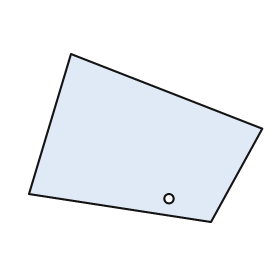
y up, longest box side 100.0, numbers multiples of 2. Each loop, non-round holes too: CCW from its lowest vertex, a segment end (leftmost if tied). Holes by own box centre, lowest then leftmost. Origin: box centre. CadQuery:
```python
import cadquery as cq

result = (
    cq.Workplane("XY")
    .moveTo(28.0, -36.0)
    .lineTo(50.0, 4.0)
    .lineTo(-32.0, 36.0)
    .lineTo(-50.0, -24.0)
    .close()
    .moveTo(10.0, -26.0)
    .circle(2.0)
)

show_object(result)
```